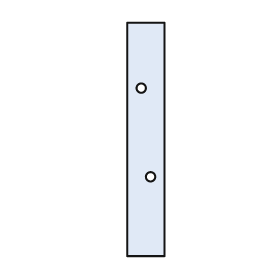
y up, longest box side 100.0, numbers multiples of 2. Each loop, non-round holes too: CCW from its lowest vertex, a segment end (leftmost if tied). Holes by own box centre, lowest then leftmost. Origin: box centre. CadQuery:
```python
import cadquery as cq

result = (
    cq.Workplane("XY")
    .moveTo(-8.0, -50.0)
    .lineTo(8.0, -50.0)
    .lineTo(8.0, 50.0)
    .lineTo(-8.0, 50.0)
    .close()
    .moveTo(2.0, -16.0)
    .circle(2.0)
    .moveTo(-2.0, 22.0)
    .circle(2.0)
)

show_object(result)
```